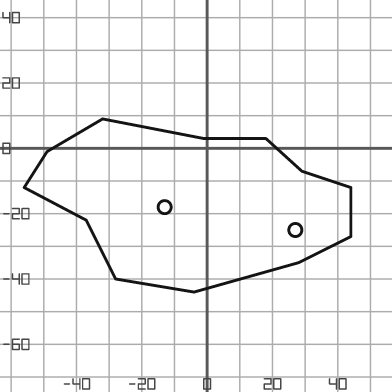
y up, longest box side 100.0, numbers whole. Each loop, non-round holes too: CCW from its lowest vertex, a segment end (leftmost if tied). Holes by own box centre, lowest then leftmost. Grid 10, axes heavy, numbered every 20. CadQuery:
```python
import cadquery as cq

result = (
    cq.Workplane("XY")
    .moveTo(-4.0, -44.0)
    .lineTo(28.0, -35.0)
    .lineTo(44.0, -27.0)
    .lineTo(44.0, -12.0)
    .lineTo(29.0, -7.0)
    .lineTo(18.0, 3.0)
    .lineTo(-1.0, 3.0)
    .lineTo(-32.0, 9.0)
    .lineTo(-49.0, -1.0)
    .lineTo(-56.0, -12.0)
    .lineTo(-37.0, -22.0)
    .lineTo(-28.0, -40.0)
    .close()
    .moveTo(27.0, -25.0)
    .circle(2.0)
    .moveTo(-13.0, -18.0)
    .circle(2.0)
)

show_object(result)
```